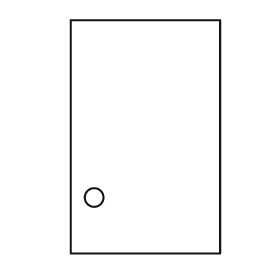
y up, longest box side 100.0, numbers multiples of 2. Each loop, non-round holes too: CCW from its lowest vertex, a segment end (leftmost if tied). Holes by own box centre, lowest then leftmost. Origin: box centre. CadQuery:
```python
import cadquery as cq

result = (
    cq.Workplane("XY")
    .moveTo(-32.0, -50.0)
    .lineTo(32.0, -50.0)
    .lineTo(32.0, 50.0)
    .lineTo(-32.0, 50.0)
    .close()
    .moveTo(-22.0, -26.0)
    .circle(4.0)
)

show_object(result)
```